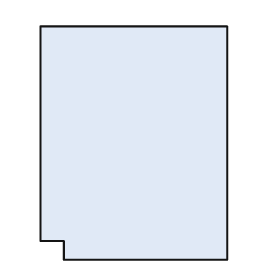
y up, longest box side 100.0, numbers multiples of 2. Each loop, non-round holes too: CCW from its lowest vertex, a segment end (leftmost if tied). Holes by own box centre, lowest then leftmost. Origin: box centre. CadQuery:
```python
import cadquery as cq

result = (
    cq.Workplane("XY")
    .moveTo(-30.0, -50.0)
    .lineTo(40.0, -50.0)
    .lineTo(40.0, 50.0)
    .lineTo(-40.0, 50.0)
    .lineTo(-40.0, -42.0)
    .lineTo(-30.0, -42.0)
    .close()
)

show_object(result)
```